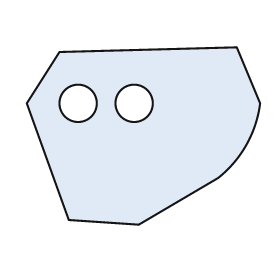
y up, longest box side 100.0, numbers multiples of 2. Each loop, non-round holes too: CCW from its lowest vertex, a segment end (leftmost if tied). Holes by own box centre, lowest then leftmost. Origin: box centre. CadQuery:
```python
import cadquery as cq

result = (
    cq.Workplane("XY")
    .moveTo(-2.0, -38.0)
    .lineTo(32.0, -18.0)
    .threePointArc((44.0, -4.0), (50.0, 14.0))
    .lineTo(40.0, 38.0)
    .lineTo(-36.0, 36.0)
    .lineTo(-50.0, 14.0)
    .lineTo(-32.0, -36.0)
    .close()
    .moveTo(-28.0, 14.0)
    .circle(8.0)
    .moveTo(-4.0, 14.0)
    .circle(8.0)
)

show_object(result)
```